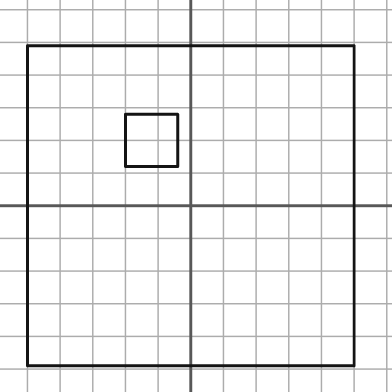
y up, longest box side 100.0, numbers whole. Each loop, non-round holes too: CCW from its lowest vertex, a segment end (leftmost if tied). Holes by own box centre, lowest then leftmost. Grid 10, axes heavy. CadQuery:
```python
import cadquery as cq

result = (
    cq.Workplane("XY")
    .moveTo(-50.0, -49.0)
    .lineTo(50.0, -49.0)
    .lineTo(50.0, 49.0)
    .lineTo(-50.0, 49.0)
    .close()
    .moveTo(-20.0, 12.0)
    .lineTo(-4.0, 12.0)
    .lineTo(-4.0, 28.0)
    .lineTo(-20.0, 28.0)
    .close()
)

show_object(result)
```